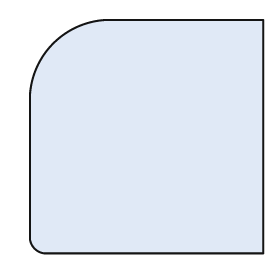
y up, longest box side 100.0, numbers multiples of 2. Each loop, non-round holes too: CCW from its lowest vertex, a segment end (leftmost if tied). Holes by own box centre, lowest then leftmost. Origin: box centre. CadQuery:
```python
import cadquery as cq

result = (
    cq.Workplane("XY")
    .moveTo(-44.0, -50.0)
    .lineTo(50.0, -50.0)
    .lineTo(50.0, 50.0)
    .lineTo(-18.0, 50.0)
    .threePointArc((-40.0, 40.0), (-50.0, 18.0))
    .lineTo(-50.0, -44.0)
    .threePointArc((-48.0, -48.0), (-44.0, -50.0))
    .close()
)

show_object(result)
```